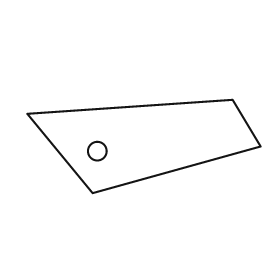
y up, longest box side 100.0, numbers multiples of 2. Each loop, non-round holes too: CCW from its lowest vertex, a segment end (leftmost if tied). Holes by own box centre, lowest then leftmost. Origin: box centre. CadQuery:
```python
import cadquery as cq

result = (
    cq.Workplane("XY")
    .moveTo(-22.0, -20.0)
    .lineTo(50.0, 0.0)
    .lineTo(38.0, 20.0)
    .lineTo(-50.0, 14.0)
    .close()
    .moveTo(-20.0, -2.0)
    .circle(4.0)
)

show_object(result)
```